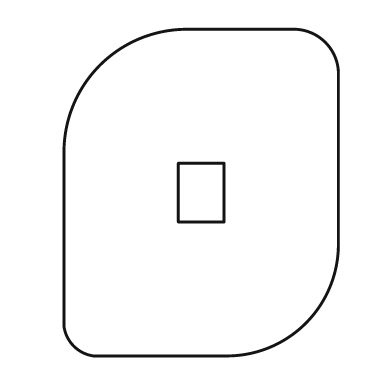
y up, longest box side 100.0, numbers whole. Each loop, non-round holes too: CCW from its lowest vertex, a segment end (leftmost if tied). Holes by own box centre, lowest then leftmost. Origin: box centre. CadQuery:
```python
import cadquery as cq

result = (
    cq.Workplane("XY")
    .moveTo(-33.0, -50.0)
    .lineTo(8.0, -50.0)
    .threePointArc((32.0, -40.0), (42.0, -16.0))
    .lineTo(42.0, 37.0)
    .threePointArc((38.0, 46.0), (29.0, 50.0))
    .lineTo(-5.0, 50.0)
    .threePointArc((-31.0, 39.0), (-42.0, 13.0))
    .lineTo(-42.0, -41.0)
    .threePointArc((-39.0, -47.0), (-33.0, -50.0))
    .close()
    .moveTo(-7.0, -9.0)
    .lineTo(7.0, -9.0)
    .lineTo(7.0, 9.0)
    .lineTo(-7.0, 9.0)
    .close()
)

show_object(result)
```